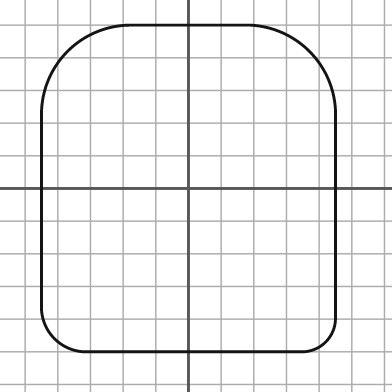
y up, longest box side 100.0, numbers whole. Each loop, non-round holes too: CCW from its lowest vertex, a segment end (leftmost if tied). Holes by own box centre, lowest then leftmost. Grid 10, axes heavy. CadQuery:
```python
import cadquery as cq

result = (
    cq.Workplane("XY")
    .moveTo(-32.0, -50.0)
    .lineTo(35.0, -50.0)
    .threePointArc((42.0, -47.0), (45.0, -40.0))
    .lineTo(45.0, 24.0)
    .threePointArc((37.0, 42.0), (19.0, 50.0))
    .lineTo(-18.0, 50.0)
    .threePointArc((-37.0, 42.0), (-45.0, 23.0))
    .lineTo(-45.0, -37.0)
    .threePointArc((-41.0, -46.0), (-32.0, -50.0))
    .close()
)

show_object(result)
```